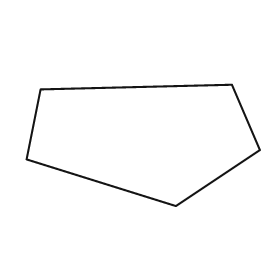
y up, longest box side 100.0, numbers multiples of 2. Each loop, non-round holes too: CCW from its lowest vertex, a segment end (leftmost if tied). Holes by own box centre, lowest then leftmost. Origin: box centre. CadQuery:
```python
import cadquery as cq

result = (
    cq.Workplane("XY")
    .moveTo(14.0, -26.0)
    .lineTo(50.0, -2.0)
    .lineTo(38.0, 26.0)
    .lineTo(-44.0, 24.0)
    .lineTo(-50.0, -6.0)
    .close()
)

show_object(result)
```